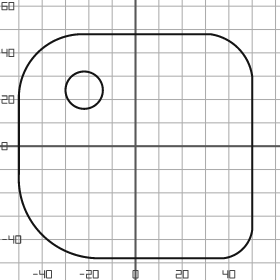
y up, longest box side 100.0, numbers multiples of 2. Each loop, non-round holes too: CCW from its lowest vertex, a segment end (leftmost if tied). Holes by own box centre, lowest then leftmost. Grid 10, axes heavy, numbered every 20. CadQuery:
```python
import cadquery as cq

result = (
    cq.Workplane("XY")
    .moveTo(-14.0, -48.0)
    .lineTo(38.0, -48.0)
    .threePointArc((46.0, -44.0), (50.0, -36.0))
    .lineTo(50.0, 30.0)
    .threePointArc((44.0, 42.0), (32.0, 48.0))
    .lineTo(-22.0, 48.0)
    .threePointArc((-42.0, 40.0), (-50.0, 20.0))
    .lineTo(-50.0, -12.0)
    .threePointArc((-40.0, -38.0), (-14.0, -48.0))
    .close()
    .moveTo(-22.0, 24.0)
    .circle(8.0)
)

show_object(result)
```